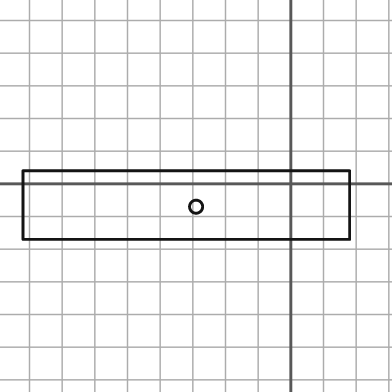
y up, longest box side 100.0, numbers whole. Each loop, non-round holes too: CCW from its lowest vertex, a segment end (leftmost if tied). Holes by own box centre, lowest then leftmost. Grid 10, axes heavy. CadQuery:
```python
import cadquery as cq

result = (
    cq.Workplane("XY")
    .moveTo(-82.0, -17.0)
    .lineTo(18.0, -17.0)
    .lineTo(18.0, 4.0)
    .lineTo(-82.0, 4.0)
    .close()
    .moveTo(-29.0, -7.0)
    .circle(2.0)
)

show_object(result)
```